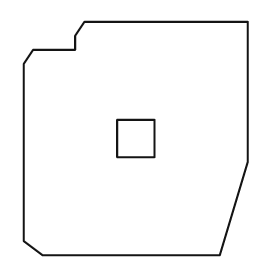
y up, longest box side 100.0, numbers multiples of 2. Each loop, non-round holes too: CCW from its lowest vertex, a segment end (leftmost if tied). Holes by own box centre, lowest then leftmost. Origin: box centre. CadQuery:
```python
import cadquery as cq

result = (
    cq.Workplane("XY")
    .moveTo(-40.0, -50.0)
    .lineTo(36.0, -50.0)
    .lineTo(48.0, -10.0)
    .lineTo(48.0, 50.0)
    .lineTo(-22.0, 50.0)
    .lineTo(-26.0, 44.0)
    .lineTo(-26.0, 38.0)
    .lineTo(-44.0, 38.0)
    .lineTo(-48.0, 32.0)
    .lineTo(-48.0, -44.0)
    .close()
    .moveTo(-8.0, -8.0)
    .lineTo(8.0, -8.0)
    .lineTo(8.0, 8.0)
    .lineTo(-8.0, 8.0)
    .close()
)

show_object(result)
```